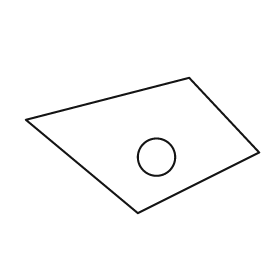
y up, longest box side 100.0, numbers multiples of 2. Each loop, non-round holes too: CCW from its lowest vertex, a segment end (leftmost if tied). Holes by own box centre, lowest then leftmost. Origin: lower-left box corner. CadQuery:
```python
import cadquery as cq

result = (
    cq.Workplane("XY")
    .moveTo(48.0, 0.0)
    .lineTo(100.0, 26.0)
    .lineTo(70.0, 58.0)
    .lineTo(0.0, 40.0)
    .close()
    .moveTo(56.0, 24.0)
    .circle(8.0)
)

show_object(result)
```